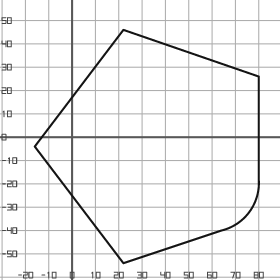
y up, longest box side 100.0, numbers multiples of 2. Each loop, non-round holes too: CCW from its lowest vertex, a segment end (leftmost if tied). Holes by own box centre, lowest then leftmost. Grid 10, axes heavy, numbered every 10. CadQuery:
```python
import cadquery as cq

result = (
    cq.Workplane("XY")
    .moveTo(22.0, -54.0)
    .lineTo(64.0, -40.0)
    .threePointArc((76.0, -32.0), (80.0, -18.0))
    .lineTo(80.0, 26.0)
    .lineTo(22.0, 46.0)
    .lineTo(-16.0, -4.0)
    .close()
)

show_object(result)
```